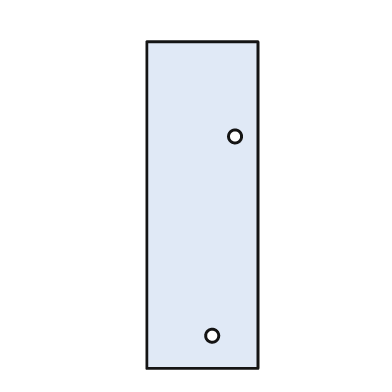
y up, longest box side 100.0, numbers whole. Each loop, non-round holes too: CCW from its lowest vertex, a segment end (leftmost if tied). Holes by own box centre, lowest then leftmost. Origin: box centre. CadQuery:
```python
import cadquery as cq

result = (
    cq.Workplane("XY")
    .moveTo(-17.0, -50.0)
    .lineTo(17.0, -50.0)
    .lineTo(17.0, 50.0)
    .lineTo(-17.0, 50.0)
    .close()
    .moveTo(3.0, -40.0)
    .circle(2.0)
    .moveTo(10.0, 21.0)
    .circle(2.0)
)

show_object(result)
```